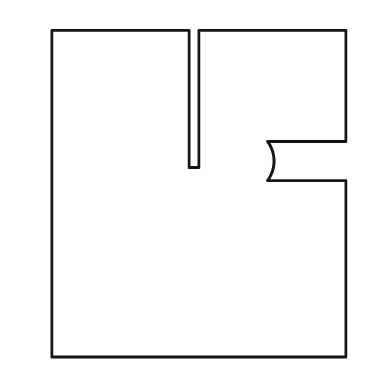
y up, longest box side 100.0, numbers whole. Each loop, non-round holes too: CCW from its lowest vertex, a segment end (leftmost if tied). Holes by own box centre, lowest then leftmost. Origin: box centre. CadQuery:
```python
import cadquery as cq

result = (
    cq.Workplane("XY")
    .moveTo(-45.0, -50.0)
    .lineTo(45.0, -50.0)
    .lineTo(45.0, 4.0)
    .lineTo(21.0, 4.0)
    .threePointArc((23.0, 10.0), (21.0, 16.0))
    .lineTo(45.0, 16.0)
    .lineTo(45.0, 50.0)
    .lineTo(0.0, 50.0)
    .lineTo(0.0, 8.0)
    .lineTo(-3.0, 8.0)
    .lineTo(-3.0, 50.0)
    .lineTo(-45.0, 50.0)
    .close()
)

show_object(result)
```